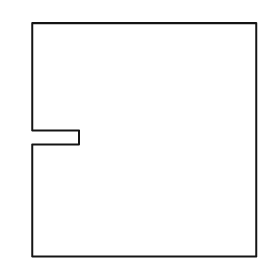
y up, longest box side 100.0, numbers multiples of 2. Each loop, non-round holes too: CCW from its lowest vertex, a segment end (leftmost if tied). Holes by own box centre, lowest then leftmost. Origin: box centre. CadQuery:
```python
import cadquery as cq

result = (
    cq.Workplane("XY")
    .moveTo(-48.0, -50.0)
    .lineTo(48.0, -50.0)
    .lineTo(48.0, 50.0)
    .lineTo(-48.0, 50.0)
    .lineTo(-48.0, 4.0)
    .lineTo(-28.0, 4.0)
    .lineTo(-28.0, -2.0)
    .lineTo(-48.0, -2.0)
    .close()
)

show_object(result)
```